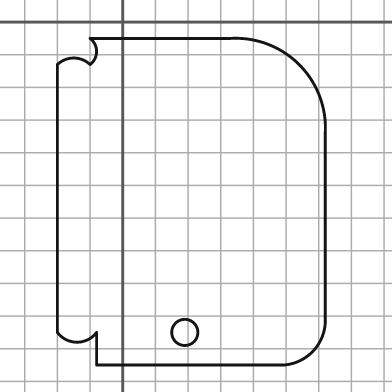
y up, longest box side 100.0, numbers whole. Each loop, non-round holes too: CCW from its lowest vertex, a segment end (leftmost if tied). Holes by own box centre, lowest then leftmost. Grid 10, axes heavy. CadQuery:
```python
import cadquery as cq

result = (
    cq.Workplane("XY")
    .moveTo(-8.0, -105.0)
    .lineTo(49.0, -105.0)
    .threePointArc((58.0, -101.0), (62.0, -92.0))
    .lineTo(62.0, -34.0)
    .threePointArc((54.0, -13.0), (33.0, -5.0))
    .lineTo(-10.0, -5.0)
    .threePointArc((-8.0, -9.0), (-10.0, -13.0))
    .threePointArc((-15.0, -11.0), (-20.0, -13.0))
    .lineTo(-20.0, -95.0)
    .threePointArc((-14.0, -98.0), (-8.0, -95.0))
    .close()
    .moveTo(19.0, -95.0)
    .circle(4.0)
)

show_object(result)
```